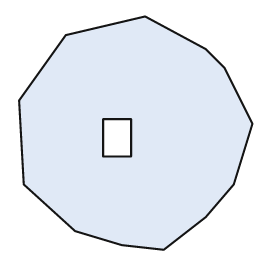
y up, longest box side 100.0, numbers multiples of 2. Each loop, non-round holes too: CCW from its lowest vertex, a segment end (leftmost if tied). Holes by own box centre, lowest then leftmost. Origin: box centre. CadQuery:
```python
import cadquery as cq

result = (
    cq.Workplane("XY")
    .moveTo(12.0, -50.0)
    .lineTo(30.0, -36.0)
    .lineTo(42.0, -22.0)
    .lineTo(50.0, 4.0)
    .lineTo(38.0, 28.0)
    .lineTo(30.0, 36.0)
    .lineTo(4.0, 50.0)
    .lineTo(-30.0, 42.0)
    .lineTo(-50.0, 14.0)
    .lineTo(-48.0, -22.0)
    .lineTo(-26.0, -42.0)
    .lineTo(-6.0, -48.0)
    .close()
    .moveTo(-14.0, -10.0)
    .lineTo(-2.0, -10.0)
    .lineTo(-2.0, 6.0)
    .lineTo(-14.0, 6.0)
    .close()
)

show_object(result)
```